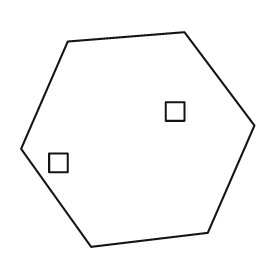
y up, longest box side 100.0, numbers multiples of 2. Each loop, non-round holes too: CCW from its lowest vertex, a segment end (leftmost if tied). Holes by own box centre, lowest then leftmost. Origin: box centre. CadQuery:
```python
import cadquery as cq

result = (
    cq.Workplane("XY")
    .moveTo(-20.0, -46.0)
    .lineTo(30.0, -40.0)
    .lineTo(50.0, 6.0)
    .lineTo(20.0, 46.0)
    .lineTo(-30.0, 42.0)
    .lineTo(-50.0, -4.0)
    .close()
    .moveTo(-38.0, -14.0)
    .lineTo(-30.0, -14.0)
    .lineTo(-30.0, -6.0)
    .lineTo(-38.0, -6.0)
    .close()
    .moveTo(12.0, 8.0)
    .lineTo(20.0, 8.0)
    .lineTo(20.0, 16.0)
    .lineTo(12.0, 16.0)
    .close()
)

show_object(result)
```